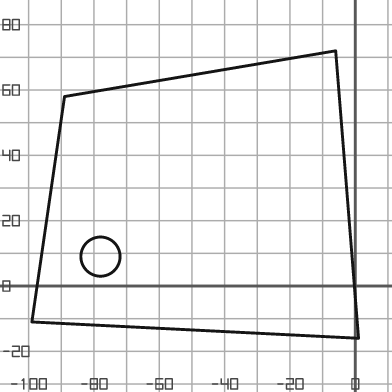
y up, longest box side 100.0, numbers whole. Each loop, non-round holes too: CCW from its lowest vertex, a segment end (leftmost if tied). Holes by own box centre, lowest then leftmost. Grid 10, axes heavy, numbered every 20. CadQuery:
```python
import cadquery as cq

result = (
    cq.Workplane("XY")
    .moveTo(1.0, -16.0)
    .lineTo(-6.0, 72.0)
    .lineTo(-89.0, 58.0)
    .lineTo(-99.0, -11.0)
    .close()
    .moveTo(-78.0, 9.0)
    .circle(6.0)
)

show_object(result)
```